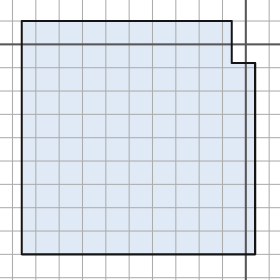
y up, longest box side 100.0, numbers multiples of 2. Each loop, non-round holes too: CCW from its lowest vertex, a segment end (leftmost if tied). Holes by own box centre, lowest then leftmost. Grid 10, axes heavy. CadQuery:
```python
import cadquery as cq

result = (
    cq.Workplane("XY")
    .moveTo(-96.0, -90.0)
    .lineTo(4.0, -90.0)
    .lineTo(4.0, -8.0)
    .lineTo(-6.0, -8.0)
    .lineTo(-6.0, 10.0)
    .lineTo(-96.0, 10.0)
    .close()
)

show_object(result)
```